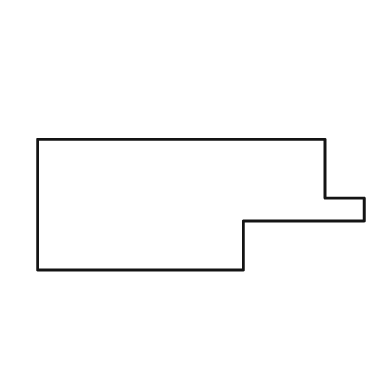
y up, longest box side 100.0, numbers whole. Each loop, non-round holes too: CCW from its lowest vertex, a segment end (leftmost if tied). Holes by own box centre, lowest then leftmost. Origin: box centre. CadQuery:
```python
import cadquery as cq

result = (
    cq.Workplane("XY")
    .moveTo(-50.0, -20.0)
    .lineTo(13.0, -20.0)
    .lineTo(13.0, -5.0)
    .lineTo(50.0, -5.0)
    .lineTo(50.0, 2.0)
    .lineTo(38.0, 2.0)
    .lineTo(38.0, 20.0)
    .lineTo(-50.0, 20.0)
    .close()
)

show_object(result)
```